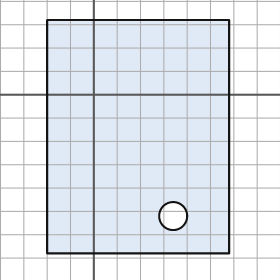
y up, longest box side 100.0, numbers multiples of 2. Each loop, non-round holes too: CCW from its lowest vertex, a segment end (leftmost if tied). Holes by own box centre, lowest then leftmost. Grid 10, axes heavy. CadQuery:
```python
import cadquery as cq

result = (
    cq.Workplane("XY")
    .moveTo(-20.0, -68.0)
    .lineTo(58.0, -68.0)
    .lineTo(58.0, 32.0)
    .lineTo(-20.0, 32.0)
    .close()
    .moveTo(34.0, -52.0)
    .circle(6.0)
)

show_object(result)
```